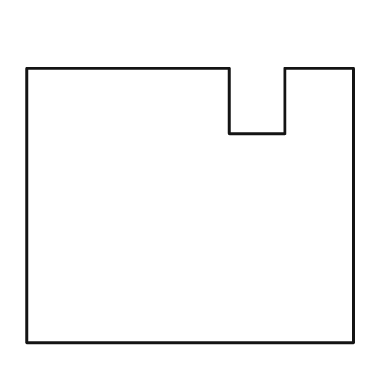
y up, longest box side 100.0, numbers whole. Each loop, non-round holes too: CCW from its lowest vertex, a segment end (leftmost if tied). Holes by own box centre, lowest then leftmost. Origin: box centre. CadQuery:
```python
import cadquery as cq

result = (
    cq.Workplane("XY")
    .moveTo(-50.0, -42.0)
    .lineTo(50.0, -42.0)
    .lineTo(50.0, 42.0)
    .lineTo(29.0, 42.0)
    .lineTo(29.0, 22.0)
    .lineTo(12.0, 22.0)
    .lineTo(12.0, 42.0)
    .lineTo(-50.0, 42.0)
    .close()
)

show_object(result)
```